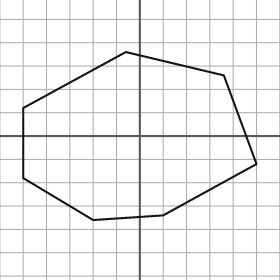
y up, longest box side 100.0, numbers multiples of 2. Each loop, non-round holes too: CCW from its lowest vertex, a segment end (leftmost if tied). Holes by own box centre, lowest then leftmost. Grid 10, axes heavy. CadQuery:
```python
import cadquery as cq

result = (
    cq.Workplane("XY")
    .moveTo(-20.0, -36.0)
    .lineTo(10.0, -34.0)
    .lineTo(50.0, -12.0)
    .lineTo(36.0, 26.0)
    .lineTo(-6.0, 36.0)
    .lineTo(-50.0, 12.0)
    .lineTo(-50.0, -18.0)
    .close()
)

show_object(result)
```